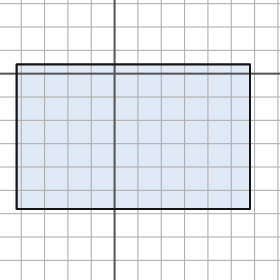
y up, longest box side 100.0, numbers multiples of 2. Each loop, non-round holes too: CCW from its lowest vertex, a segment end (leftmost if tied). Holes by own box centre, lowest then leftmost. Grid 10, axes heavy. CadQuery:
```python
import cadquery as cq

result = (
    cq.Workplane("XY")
    .moveTo(-42.0, -58.0)
    .lineTo(58.0, -58.0)
    .lineTo(58.0, 4.0)
    .lineTo(-42.0, 4.0)
    .close()
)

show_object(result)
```